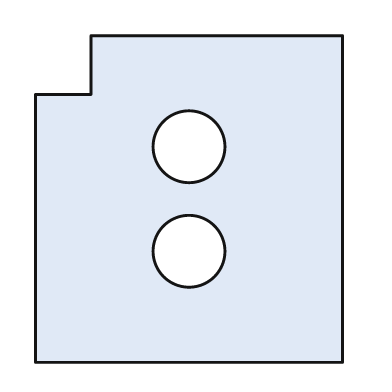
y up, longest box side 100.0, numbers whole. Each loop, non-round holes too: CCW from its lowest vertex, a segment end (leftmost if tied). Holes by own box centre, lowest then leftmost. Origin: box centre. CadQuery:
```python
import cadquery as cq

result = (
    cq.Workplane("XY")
    .moveTo(-47.0, -50.0)
    .lineTo(47.0, -50.0)
    .lineTo(47.0, 50.0)
    .lineTo(-30.0, 50.0)
    .lineTo(-30.0, 32.0)
    .lineTo(-47.0, 32.0)
    .close()
    .moveTo(0.0, -16.0)
    .circle(11.0)
    .moveTo(0.0, 16.0)
    .circle(11.0)
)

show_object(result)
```